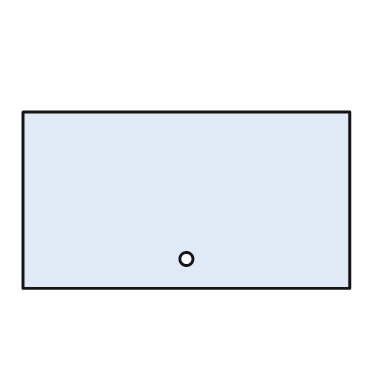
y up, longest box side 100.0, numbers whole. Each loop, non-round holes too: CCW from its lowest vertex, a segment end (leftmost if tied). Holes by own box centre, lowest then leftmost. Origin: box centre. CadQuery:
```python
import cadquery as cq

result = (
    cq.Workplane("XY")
    .moveTo(-50.0, -27.0)
    .lineTo(50.0, -27.0)
    .lineTo(50.0, 27.0)
    .lineTo(-50.0, 27.0)
    .close()
    .moveTo(0.0, -18.0)
    .circle(2.0)
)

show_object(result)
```